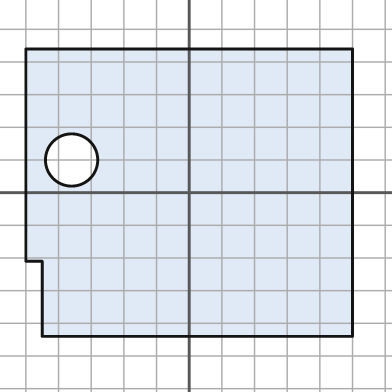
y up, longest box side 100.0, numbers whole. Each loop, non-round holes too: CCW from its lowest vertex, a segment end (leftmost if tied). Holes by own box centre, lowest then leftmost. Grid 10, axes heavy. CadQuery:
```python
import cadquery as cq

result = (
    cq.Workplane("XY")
    .moveTo(-45.0, -44.0)
    .lineTo(50.0, -44.0)
    .lineTo(50.0, 44.0)
    .lineTo(-50.0, 44.0)
    .lineTo(-50.0, -21.0)
    .lineTo(-45.0, -21.0)
    .close()
    .moveTo(-36.0, 10.0)
    .circle(8.0)
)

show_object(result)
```